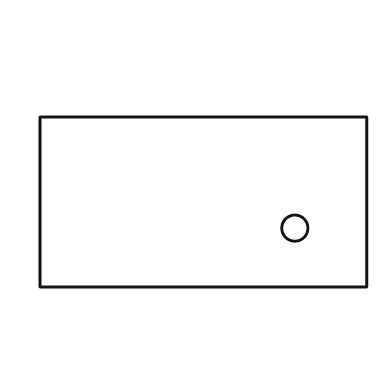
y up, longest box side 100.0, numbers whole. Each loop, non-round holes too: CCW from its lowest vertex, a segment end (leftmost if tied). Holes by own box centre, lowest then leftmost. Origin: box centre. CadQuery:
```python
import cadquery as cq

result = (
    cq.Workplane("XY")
    .moveTo(-50.0, -26.0)
    .lineTo(50.0, -26.0)
    .lineTo(50.0, 26.0)
    .lineTo(-50.0, 26.0)
    .close()
    .moveTo(28.0, -8.0)
    .circle(4.0)
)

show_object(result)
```